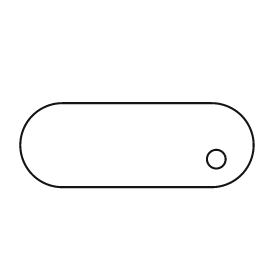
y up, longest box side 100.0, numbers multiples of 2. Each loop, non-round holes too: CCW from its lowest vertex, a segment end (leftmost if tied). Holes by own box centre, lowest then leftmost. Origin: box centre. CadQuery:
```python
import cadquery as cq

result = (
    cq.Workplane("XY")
    .moveTo(-32.0, -18.0)
    .lineTo(32.0, -18.0)
    .threePointArc((50.0, 0.0), (32.0, 18.0))
    .lineTo(-32.0, 18.0)
    .threePointArc((-50.0, 0.0), (-32.0, -18.0))
    .close()
    .moveTo(34.0, -6.0)
    .circle(4.0)
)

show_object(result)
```